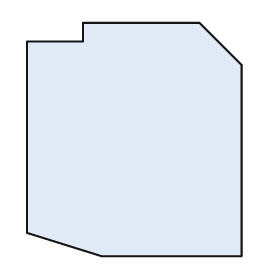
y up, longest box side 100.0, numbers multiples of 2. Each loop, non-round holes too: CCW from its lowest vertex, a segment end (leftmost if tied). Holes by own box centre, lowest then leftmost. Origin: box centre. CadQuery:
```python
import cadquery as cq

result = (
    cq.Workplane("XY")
    .moveTo(-14.0, -50.0)
    .lineTo(46.0, -50.0)
    .lineTo(46.0, 32.0)
    .lineTo(28.0, 50.0)
    .lineTo(-22.0, 50.0)
    .lineTo(-22.0, 42.0)
    .lineTo(-46.0, 42.0)
    .lineTo(-46.0, -40.0)
    .close()
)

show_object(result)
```